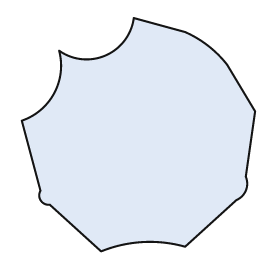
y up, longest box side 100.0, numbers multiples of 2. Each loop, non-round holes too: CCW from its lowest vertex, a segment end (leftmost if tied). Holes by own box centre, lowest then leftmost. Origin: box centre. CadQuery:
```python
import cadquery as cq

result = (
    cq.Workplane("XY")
    .moveTo(-16.0, -50.0)
    .threePointArc((2.0, -46.0), (20.0, -48.0))
    .lineTo(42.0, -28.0)
    .threePointArc((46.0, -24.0), (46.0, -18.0))
    .lineTo(50.0, 10.0)
    .lineTo(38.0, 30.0)
    .threePointArc((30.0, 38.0), (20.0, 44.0))
    .lineTo(-2.0, 50.0)
    .threePointArc((-14.0, 34.0), (-34.0, 36.0))
    .threePointArc((-36.0, 18.0), (-50.0, 6.0))
    .lineTo(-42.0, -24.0)
    .threePointArc((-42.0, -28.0), (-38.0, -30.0))
    .close()
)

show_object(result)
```